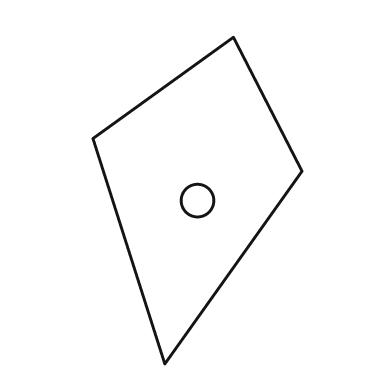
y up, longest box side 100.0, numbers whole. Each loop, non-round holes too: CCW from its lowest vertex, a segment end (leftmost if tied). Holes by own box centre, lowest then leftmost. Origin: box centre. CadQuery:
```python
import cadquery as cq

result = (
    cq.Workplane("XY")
    .moveTo(-10.0, -50.0)
    .lineTo(32.0, 9.0)
    .lineTo(11.0, 50.0)
    .lineTo(-32.0, 19.0)
    .close()
    .moveTo(0.0, 0.0)
    .circle(5.0)
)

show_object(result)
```